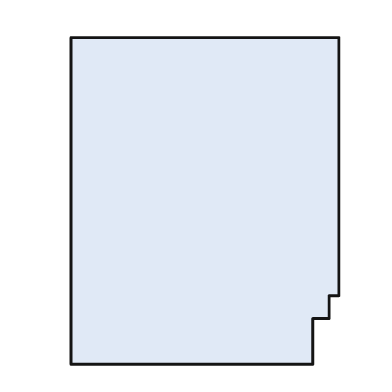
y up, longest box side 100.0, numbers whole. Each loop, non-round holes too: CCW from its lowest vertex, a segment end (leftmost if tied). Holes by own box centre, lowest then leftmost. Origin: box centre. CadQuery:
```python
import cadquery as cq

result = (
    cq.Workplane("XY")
    .moveTo(-41.0, -50.0)
    .lineTo(33.0, -50.0)
    .lineTo(33.0, -36.0)
    .lineTo(38.0, -36.0)
    .lineTo(38.0, -29.0)
    .lineTo(41.0, -29.0)
    .lineTo(41.0, 50.0)
    .lineTo(-41.0, 50.0)
    .close()
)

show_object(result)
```